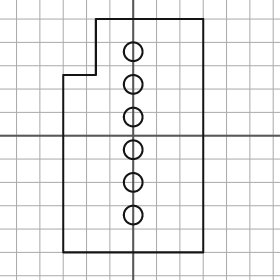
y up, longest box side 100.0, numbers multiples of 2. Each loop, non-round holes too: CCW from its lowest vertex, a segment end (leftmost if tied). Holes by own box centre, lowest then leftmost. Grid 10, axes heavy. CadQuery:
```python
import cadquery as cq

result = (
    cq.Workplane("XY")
    .moveTo(-30.0, -50.0)
    .lineTo(30.0, -50.0)
    .lineTo(30.0, 50.0)
    .lineTo(-16.0, 50.0)
    .lineTo(-16.0, 26.0)
    .lineTo(-30.0, 26.0)
    .close()
    .moveTo(0.0, -34.0)
    .circle(4.0)
    .moveTo(0.0, -20.0)
    .circle(4.0)
    .moveTo(0.0, -6.0)
    .circle(4.0)
    .moveTo(0.0, 8.0)
    .circle(4.0)
    .moveTo(0.0, 22.0)
    .circle(4.0)
    .moveTo(0.0, 36.0)
    .circle(4.0)
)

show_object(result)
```